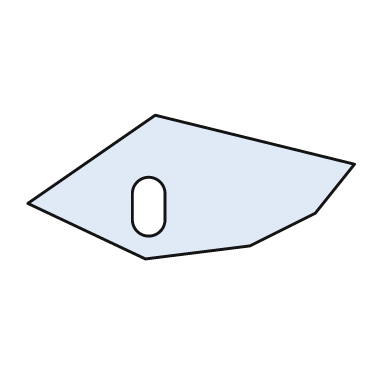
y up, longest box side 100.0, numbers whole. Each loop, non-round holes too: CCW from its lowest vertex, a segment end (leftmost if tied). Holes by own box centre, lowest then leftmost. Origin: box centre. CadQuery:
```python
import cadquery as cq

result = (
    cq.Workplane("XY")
    .moveTo(-14.0, -22.0)
    .lineTo(18.0, -18.0)
    .lineTo(38.0, -8.0)
    .lineTo(50.0, 7.0)
    .lineTo(-11.0, 22.0)
    .lineTo(-50.0, -5.0)
    .close()
    .moveTo(-18.0, -10.0)
    .threePointArc((-13.0, -15.0), (-8.0, -10.0))
    .lineTo(-8.0, -2.0)
    .threePointArc((-13.0, 3.0), (-18.0, -2.0))
    .close()
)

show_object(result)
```